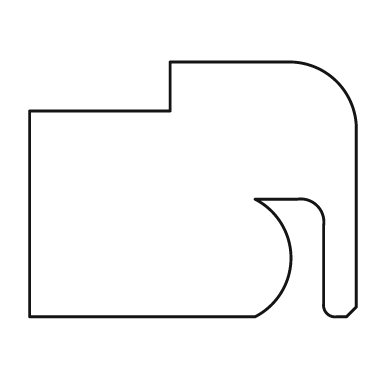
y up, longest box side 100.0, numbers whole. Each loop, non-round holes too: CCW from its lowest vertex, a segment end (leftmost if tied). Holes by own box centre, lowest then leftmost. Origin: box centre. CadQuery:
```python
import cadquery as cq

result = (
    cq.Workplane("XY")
    .moveTo(-50.0, -39.0)
    .lineTo(19.0, -39.0)
    .threePointArc((30.0, -21.0), (19.0, -3.0))
    .lineTo(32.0, -3.0)
    .threePointArc((38.0, -5.0), (40.0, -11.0))
    .lineTo(40.0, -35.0)
    .threePointArc((41.0, -38.0), (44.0, -39.0))
    .lineTo(47.0, -39.0)
    .lineTo(50.0, -36.0)
    .lineTo(50.0, 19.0)
    .threePointArc((44.0, 33.0), (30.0, 39.0))
    .lineTo(-7.0, 39.0)
    .lineTo(-7.0, 24.0)
    .lineTo(-50.0, 24.0)
    .close()
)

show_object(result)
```